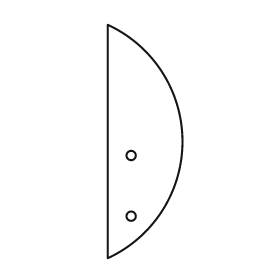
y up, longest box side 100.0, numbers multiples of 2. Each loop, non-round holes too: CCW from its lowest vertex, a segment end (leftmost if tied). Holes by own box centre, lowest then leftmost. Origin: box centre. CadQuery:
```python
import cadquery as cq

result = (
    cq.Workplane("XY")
    .moveTo(-16.0, -50.0)
    .threePointArc((16.0, 0.0), (-16.0, 50.0))
    .close()
    .moveTo(-6.0, -32.0)
    .circle(2.0)
    .moveTo(-6.0, -6.0)
    .circle(2.0)
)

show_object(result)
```